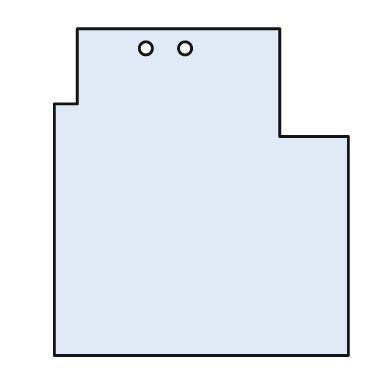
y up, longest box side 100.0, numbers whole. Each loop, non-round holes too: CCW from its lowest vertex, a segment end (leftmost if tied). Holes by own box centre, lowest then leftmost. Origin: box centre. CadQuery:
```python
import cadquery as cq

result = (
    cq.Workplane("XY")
    .moveTo(-45.0, -50.0)
    .lineTo(45.0, -50.0)
    .lineTo(45.0, 17.0)
    .lineTo(24.0, 17.0)
    .lineTo(24.0, 50.0)
    .lineTo(-38.0, 50.0)
    .lineTo(-38.0, 27.0)
    .lineTo(-45.0, 27.0)
    .close()
    .moveTo(-17.0, 44.0)
    .circle(2.0)
    .moveTo(-5.0, 44.0)
    .circle(2.0)
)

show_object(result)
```